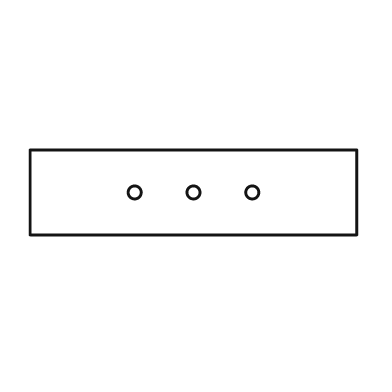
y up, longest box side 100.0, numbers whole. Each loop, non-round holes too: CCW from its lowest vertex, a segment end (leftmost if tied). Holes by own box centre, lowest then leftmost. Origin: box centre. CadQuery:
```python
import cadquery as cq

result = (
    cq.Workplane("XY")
    .moveTo(-50.0, -13.0)
    .lineTo(50.0, -13.0)
    .lineTo(50.0, 13.0)
    .lineTo(-50.0, 13.0)
    .close()
    .moveTo(-18.0, 0.0)
    .circle(2.0)
    .moveTo(0.0, 0.0)
    .circle(2.0)
    .moveTo(18.0, 0.0)
    .circle(2.0)
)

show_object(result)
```